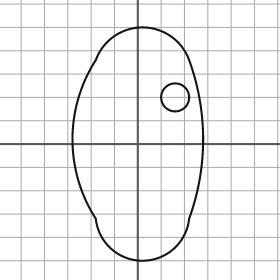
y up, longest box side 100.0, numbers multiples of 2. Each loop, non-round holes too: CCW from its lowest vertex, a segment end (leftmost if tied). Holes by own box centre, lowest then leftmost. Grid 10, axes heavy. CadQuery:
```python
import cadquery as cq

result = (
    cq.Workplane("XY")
    .moveTo(-18.0, -32.0)
    .threePointArc((2.0, -50.0), (22.0, -32.0))
    .threePointArc((28.0, 2.0), (22.0, 36.0))
    .threePointArc((2.0, 50.0), (-18.0, 36.0))
    .threePointArc((-28.0, 2.0), (-18.0, -32.0))
    .close()
    .moveTo(16.0, 20.0)
    .circle(6.0)
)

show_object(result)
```